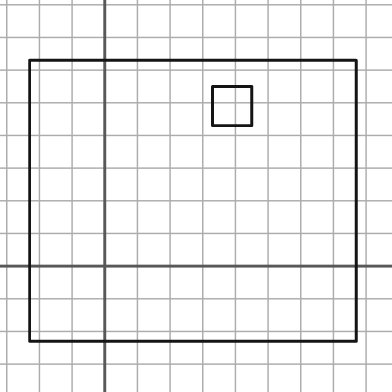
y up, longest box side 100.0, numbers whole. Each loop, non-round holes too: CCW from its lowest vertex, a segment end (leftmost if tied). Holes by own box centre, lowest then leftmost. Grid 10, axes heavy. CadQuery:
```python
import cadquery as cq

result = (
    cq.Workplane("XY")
    .moveTo(-23.0, -23.0)
    .lineTo(77.0, -23.0)
    .lineTo(77.0, 63.0)
    .lineTo(-23.0, 63.0)
    .close()
    .moveTo(33.0, 43.0)
    .lineTo(45.0, 43.0)
    .lineTo(45.0, 55.0)
    .lineTo(33.0, 55.0)
    .close()
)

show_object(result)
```